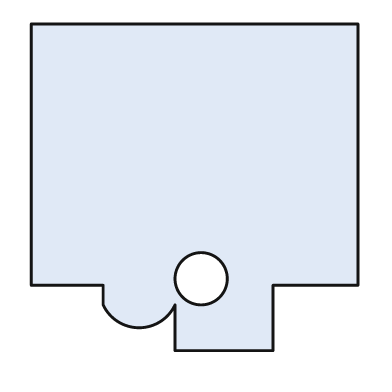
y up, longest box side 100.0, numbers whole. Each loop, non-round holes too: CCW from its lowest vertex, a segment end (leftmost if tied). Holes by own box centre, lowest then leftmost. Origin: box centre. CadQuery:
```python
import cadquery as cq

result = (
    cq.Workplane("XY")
    .moveTo(-6.0, -50.0)
    .lineTo(24.0, -50.0)
    .lineTo(24.0, -30.0)
    .lineTo(50.0, -30.0)
    .lineTo(50.0, 50.0)
    .lineTo(-50.0, 50.0)
    .lineTo(-50.0, -30.0)
    .lineTo(-28.0, -30.0)
    .lineTo(-28.0, -36.0)
    .threePointArc((-17.0, -43.0), (-6.0, -36.0))
    .close()
    .moveTo(2.0, -28.0)
    .circle(8.0)
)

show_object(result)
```